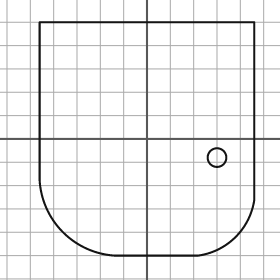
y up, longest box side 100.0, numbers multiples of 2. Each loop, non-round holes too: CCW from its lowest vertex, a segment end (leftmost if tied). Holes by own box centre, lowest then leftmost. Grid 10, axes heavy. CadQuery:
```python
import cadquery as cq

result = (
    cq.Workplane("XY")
    .moveTo(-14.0, -50.0)
    .lineTo(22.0, -50.0)
    .threePointArc((38.0, -42.0), (46.0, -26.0))
    .lineTo(46.0, 50.0)
    .lineTo(-46.0, 50.0)
    .lineTo(-46.0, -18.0)
    .threePointArc((-36.0, -40.0), (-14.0, -50.0))
    .close()
    .moveTo(30.0, -8.0)
    .circle(4.0)
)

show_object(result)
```